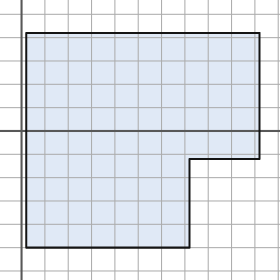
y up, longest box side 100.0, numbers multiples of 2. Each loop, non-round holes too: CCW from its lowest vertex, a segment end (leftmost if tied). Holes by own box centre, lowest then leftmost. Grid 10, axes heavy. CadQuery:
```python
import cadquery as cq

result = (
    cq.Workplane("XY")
    .moveTo(2.0, -50.0)
    .lineTo(72.0, -50.0)
    .lineTo(72.0, -12.0)
    .lineTo(102.0, -12.0)
    .lineTo(102.0, 42.0)
    .lineTo(2.0, 42.0)
    .close()
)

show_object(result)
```